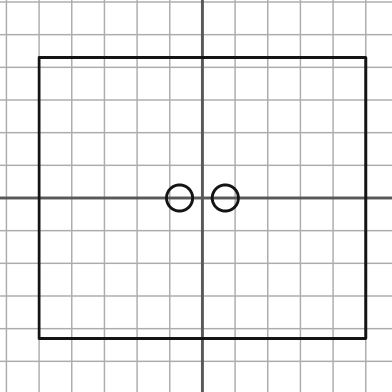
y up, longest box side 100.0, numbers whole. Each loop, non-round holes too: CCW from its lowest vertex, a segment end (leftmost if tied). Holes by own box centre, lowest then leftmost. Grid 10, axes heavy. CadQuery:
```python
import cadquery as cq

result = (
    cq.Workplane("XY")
    .moveTo(-50.0, -43.0)
    .lineTo(50.0, -43.0)
    .lineTo(50.0, 43.0)
    .lineTo(-50.0, 43.0)
    .close()
    .moveTo(-7.0, 0.0)
    .circle(4.0)
    .moveTo(7.0, 0.0)
    .circle(4.0)
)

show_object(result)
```